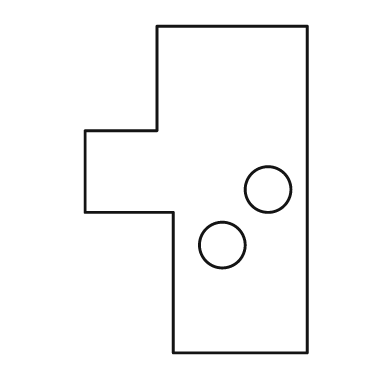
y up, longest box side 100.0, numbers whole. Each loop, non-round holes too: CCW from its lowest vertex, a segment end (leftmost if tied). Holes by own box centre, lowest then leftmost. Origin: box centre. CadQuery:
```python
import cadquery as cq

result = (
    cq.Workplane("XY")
    .moveTo(-7.0, -50.0)
    .lineTo(34.0, -50.0)
    .lineTo(34.0, 50.0)
    .lineTo(-12.0, 50.0)
    .lineTo(-12.0, 18.0)
    .lineTo(-34.0, 18.0)
    .lineTo(-34.0, -7.0)
    .lineTo(-7.0, -7.0)
    .close()
    .moveTo(8.0, -17.0)
    .circle(7.0)
    .moveTo(22.0, 0.0)
    .circle(7.0)
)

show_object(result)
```